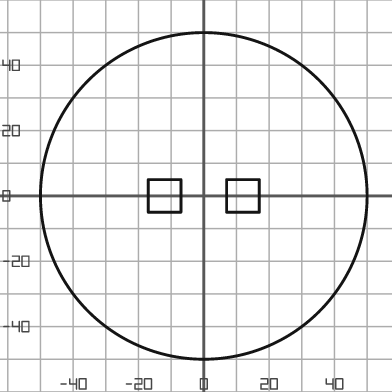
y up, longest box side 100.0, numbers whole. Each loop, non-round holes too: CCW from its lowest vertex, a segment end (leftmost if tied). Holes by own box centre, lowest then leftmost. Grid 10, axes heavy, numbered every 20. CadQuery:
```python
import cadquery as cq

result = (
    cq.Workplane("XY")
    .moveTo(0.0, 0.0)
    .circle(50.0)
    .moveTo(-17.0, -5.0)
    .lineTo(-7.0, -5.0)
    .lineTo(-7.0, 5.0)
    .lineTo(-17.0, 5.0)
    .close()
    .moveTo(7.0, -5.0)
    .lineTo(17.0, -5.0)
    .lineTo(17.0, 5.0)
    .lineTo(7.0, 5.0)
    .close()
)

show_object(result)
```